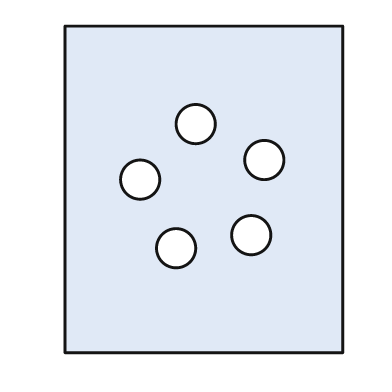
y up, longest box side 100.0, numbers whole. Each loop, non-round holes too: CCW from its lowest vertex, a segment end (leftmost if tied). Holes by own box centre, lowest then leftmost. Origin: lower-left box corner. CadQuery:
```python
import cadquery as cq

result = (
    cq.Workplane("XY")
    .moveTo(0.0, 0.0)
    .lineTo(85.0, 0.0)
    .lineTo(85.0, 100.0)
    .lineTo(0.0, 100.0)
    .close()
    .moveTo(34.0, 32.0)
    .circle(6.0)
    .moveTo(57.0, 36.0)
    .circle(6.0)
    .moveTo(23.0, 53.0)
    .circle(6.0)
    .moveTo(61.0, 59.0)
    .circle(6.0)
    .moveTo(40.0, 70.0)
    .circle(6.0)
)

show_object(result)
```